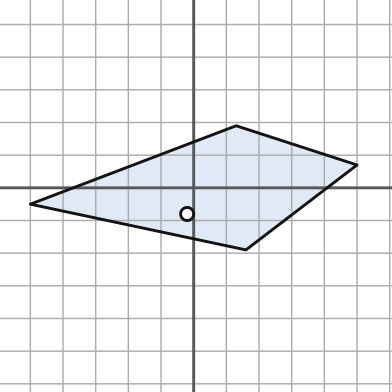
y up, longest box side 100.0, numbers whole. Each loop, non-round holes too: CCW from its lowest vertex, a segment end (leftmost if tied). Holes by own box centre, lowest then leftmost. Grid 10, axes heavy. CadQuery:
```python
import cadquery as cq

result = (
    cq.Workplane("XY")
    .moveTo(16.0, -19.0)
    .lineTo(50.0, 7.0)
    .lineTo(13.0, 19.0)
    .lineTo(-50.0, -5.0)
    .close()
    .moveTo(-2.0, -8.0)
    .circle(2.0)
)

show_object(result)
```